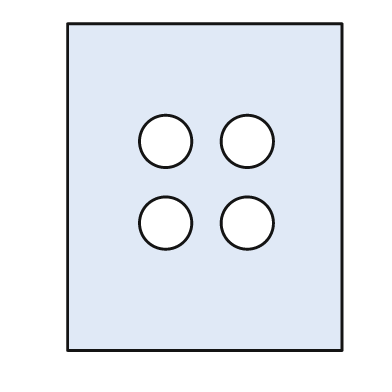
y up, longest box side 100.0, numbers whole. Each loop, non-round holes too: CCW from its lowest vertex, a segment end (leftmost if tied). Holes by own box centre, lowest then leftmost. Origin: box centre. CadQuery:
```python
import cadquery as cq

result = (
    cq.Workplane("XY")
    .moveTo(-42.0, -50.0)
    .lineTo(42.0, -50.0)
    .lineTo(42.0, 50.0)
    .lineTo(-42.0, 50.0)
    .close()
    .moveTo(-12.0, -11.0)
    .circle(8.0)
    .moveTo(13.0, -11.0)
    .circle(8.0)
    .moveTo(-12.0, 14.0)
    .circle(8.0)
    .moveTo(13.0, 14.0)
    .circle(8.0)
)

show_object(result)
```